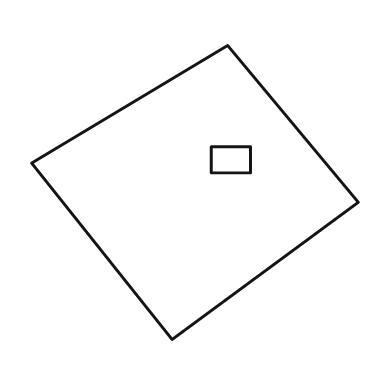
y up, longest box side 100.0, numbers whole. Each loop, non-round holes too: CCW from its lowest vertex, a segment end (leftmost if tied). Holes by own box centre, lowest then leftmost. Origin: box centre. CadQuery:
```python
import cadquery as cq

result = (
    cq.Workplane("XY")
    .moveTo(-7.0, -45.0)
    .lineTo(50.0, -3.0)
    .lineTo(10.0, 45.0)
    .lineTo(-50.0, 9.0)
    .close()
    .moveTo(5.0, 6.0)
    .lineTo(17.0, 6.0)
    .lineTo(17.0, 14.0)
    .lineTo(5.0, 14.0)
    .close()
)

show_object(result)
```